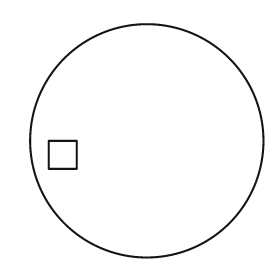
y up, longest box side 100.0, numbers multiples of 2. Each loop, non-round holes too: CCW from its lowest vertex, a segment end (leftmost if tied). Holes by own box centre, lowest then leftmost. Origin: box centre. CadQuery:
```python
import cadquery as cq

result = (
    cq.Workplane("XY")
    .moveTo(0.0, 0.0)
    .circle(50.0)
    .moveTo(-42.0, -12.0)
    .lineTo(-30.0, -12.0)
    .lineTo(-30.0, 0.0)
    .lineTo(-42.0, 0.0)
    .close()
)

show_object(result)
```